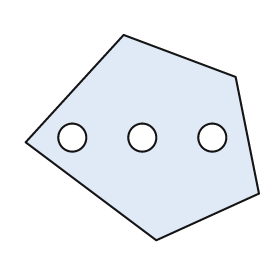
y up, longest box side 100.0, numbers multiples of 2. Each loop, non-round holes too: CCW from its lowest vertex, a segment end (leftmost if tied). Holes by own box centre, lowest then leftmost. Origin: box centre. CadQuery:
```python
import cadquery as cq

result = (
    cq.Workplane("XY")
    .moveTo(6.0, -44.0)
    .lineTo(50.0, -24.0)
    .lineTo(40.0, 26.0)
    .lineTo(-8.0, 44.0)
    .lineTo(-50.0, -2.0)
    .close()
    .moveTo(-30.0, 0.0)
    .circle(6.0)
    .moveTo(0.0, 0.0)
    .circle(6.0)
    .moveTo(30.0, 0.0)
    .circle(6.0)
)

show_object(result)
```